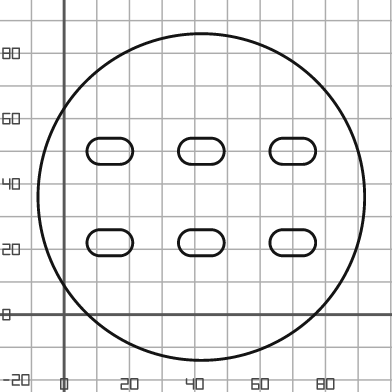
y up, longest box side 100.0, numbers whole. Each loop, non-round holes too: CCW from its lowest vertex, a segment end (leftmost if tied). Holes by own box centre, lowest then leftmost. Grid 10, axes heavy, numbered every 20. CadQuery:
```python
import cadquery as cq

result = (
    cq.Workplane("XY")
    .moveTo(42.0, 36.0)
    .circle(50.0)
    .moveTo(11.0, 18.0)
    .lineTo(17.0, 18.0)
    .threePointArc((21.0, 22.0), (17.0, 26.0))
    .lineTo(11.0, 26.0)
    .threePointArc((7.0, 22.0), (11.0, 18.0))
    .close()
    .moveTo(39.0, 18.0)
    .lineTo(45.0, 18.0)
    .threePointArc((49.0, 22.0), (45.0, 26.0))
    .lineTo(39.0, 26.0)
    .threePointArc((35.0, 22.0), (39.0, 18.0))
    .close()
    .moveTo(67.0, 18.0)
    .lineTo(73.0, 18.0)
    .threePointArc((77.0, 22.0), (73.0, 26.0))
    .lineTo(67.0, 26.0)
    .threePointArc((63.0, 22.0), (67.0, 18.0))
    .close()
    .moveTo(11.0, 46.0)
    .lineTo(17.0, 46.0)
    .threePointArc((21.0, 50.0), (17.0, 54.0))
    .lineTo(11.0, 54.0)
    .threePointArc((7.0, 50.0), (11.0, 46.0))
    .close()
    .moveTo(39.0, 46.0)
    .lineTo(45.0, 46.0)
    .threePointArc((49.0, 50.0), (45.0, 54.0))
    .lineTo(39.0, 54.0)
    .threePointArc((35.0, 50.0), (39.0, 46.0))
    .close()
    .moveTo(67.0, 46.0)
    .lineTo(73.0, 46.0)
    .threePointArc((77.0, 50.0), (73.0, 54.0))
    .lineTo(67.0, 54.0)
    .threePointArc((63.0, 50.0), (67.0, 46.0))
    .close()
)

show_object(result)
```